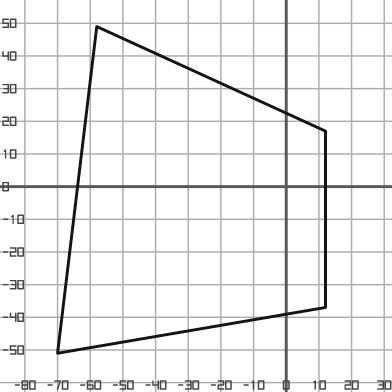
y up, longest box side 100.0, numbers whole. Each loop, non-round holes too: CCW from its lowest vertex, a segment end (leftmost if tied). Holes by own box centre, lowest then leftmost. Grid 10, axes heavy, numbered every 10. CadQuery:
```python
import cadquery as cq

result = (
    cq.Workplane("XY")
    .moveTo(-70.0, -51.0)
    .lineTo(12.0, -37.0)
    .lineTo(12.0, 17.0)
    .lineTo(-58.0, 49.0)
    .close()
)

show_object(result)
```